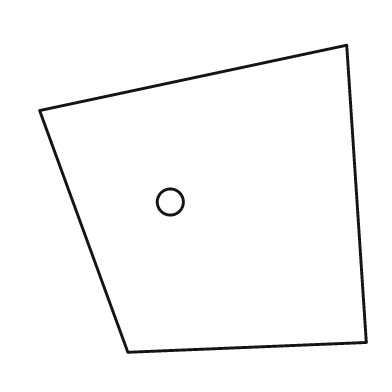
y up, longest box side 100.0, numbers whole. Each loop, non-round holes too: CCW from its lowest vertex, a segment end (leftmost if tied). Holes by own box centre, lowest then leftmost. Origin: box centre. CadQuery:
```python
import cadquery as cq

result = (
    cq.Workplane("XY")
    .moveTo(-23.0, -47.0)
    .lineTo(50.0, -44.0)
    .lineTo(44.0, 47.0)
    .lineTo(-50.0, 27.0)
    .close()
    .moveTo(-10.0, -1.0)
    .circle(4.0)
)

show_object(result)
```